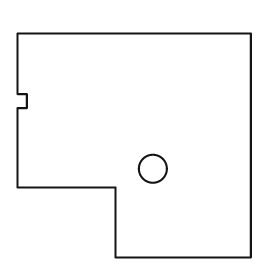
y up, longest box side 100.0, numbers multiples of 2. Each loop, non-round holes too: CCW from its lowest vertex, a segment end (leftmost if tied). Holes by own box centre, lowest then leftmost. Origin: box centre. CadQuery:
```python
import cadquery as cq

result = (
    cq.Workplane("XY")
    .moveTo(-8.0, -48.0)
    .lineTo(50.0, -48.0)
    .lineTo(50.0, 48.0)
    .lineTo(-50.0, 48.0)
    .lineTo(-50.0, 22.0)
    .lineTo(-46.0, 22.0)
    .lineTo(-46.0, 16.0)
    .lineTo(-50.0, 16.0)
    .lineTo(-50.0, -18.0)
    .lineTo(-8.0, -18.0)
    .close()
    .moveTo(8.0, -10.0)
    .circle(6.0)
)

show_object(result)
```